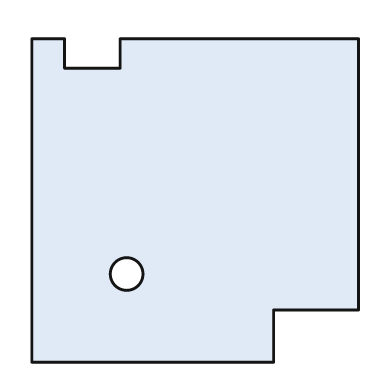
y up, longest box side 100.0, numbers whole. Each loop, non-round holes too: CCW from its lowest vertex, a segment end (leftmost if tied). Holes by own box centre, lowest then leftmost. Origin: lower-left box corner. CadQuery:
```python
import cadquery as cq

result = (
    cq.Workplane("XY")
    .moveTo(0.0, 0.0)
    .lineTo(74.0, 0.0)
    .lineTo(74.0, 16.0)
    .lineTo(100.0, 16.0)
    .lineTo(100.0, 99.0)
    .lineTo(27.0, 99.0)
    .lineTo(27.0, 90.0)
    .lineTo(10.0, 90.0)
    .lineTo(10.0, 99.0)
    .lineTo(0.0, 99.0)
    .close()
    .moveTo(29.0, 27.0)
    .circle(5.0)
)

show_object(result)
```